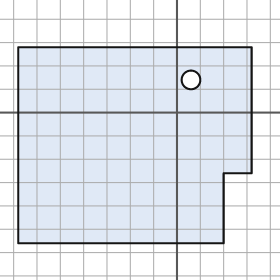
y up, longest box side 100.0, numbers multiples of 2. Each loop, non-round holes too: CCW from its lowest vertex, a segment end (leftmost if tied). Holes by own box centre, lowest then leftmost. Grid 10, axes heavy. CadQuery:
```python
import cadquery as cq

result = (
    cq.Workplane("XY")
    .moveTo(-68.0, -56.0)
    .lineTo(20.0, -56.0)
    .lineTo(20.0, -26.0)
    .lineTo(32.0, -26.0)
    .lineTo(32.0, 28.0)
    .lineTo(-68.0, 28.0)
    .close()
    .moveTo(6.0, 14.0)
    .circle(4.0)
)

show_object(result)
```